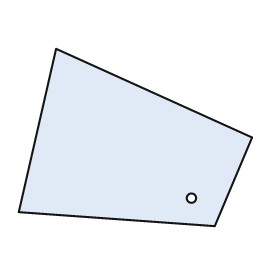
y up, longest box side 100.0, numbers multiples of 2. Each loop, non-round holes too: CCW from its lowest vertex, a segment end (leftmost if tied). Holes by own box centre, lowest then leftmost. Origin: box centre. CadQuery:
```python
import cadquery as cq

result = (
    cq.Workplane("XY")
    .moveTo(34.0, -38.0)
    .lineTo(50.0, 0.0)
    .lineTo(-34.0, 38.0)
    .lineTo(-50.0, -32.0)
    .close()
    .moveTo(24.0, -26.0)
    .circle(2.0)
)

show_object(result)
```